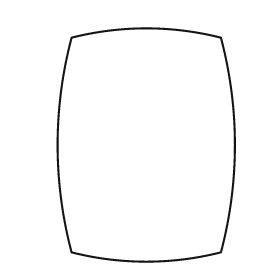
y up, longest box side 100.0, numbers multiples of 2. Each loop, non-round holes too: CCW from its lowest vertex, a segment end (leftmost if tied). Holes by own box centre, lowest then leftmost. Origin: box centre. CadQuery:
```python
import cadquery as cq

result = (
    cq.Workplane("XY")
    .moveTo(-32.0, -46.0)
    .threePointArc((0.0, -50.0), (32.0, -46.0))
    .threePointArc((38.0, 0.0), (32.0, 46.0))
    .threePointArc((0.0, 50.0), (-32.0, 46.0))
    .threePointArc((-38.0, 0.0), (-32.0, -46.0))
    .close()
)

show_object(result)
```